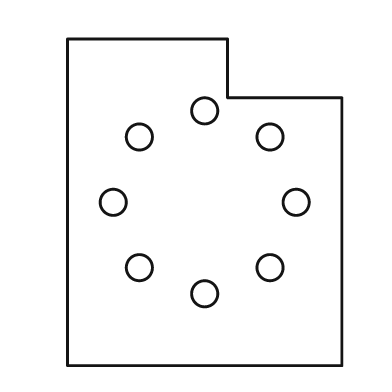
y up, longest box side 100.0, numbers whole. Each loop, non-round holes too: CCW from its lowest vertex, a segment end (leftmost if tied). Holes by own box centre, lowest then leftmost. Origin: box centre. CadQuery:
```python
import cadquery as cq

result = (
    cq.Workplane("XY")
    .moveTo(-42.0, -50.0)
    .lineTo(42.0, -50.0)
    .lineTo(42.0, 32.0)
    .lineTo(7.0, 32.0)
    .lineTo(7.0, 50.0)
    .lineTo(-42.0, 50.0)
    .close()
    .moveTo(0.0, -28.0)
    .circle(4.0)
    .moveTo(-20.0, -20.0)
    .circle(4.0)
    .moveTo(20.0, -20.0)
    .circle(4.0)
    .moveTo(-28.0, 0.0)
    .circle(4.0)
    .moveTo(28.0, 0.0)
    .circle(4.0)
    .moveTo(-20.0, 20.0)
    .circle(4.0)
    .moveTo(20.0, 20.0)
    .circle(4.0)
    .moveTo(0.0, 28.0)
    .circle(4.0)
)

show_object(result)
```